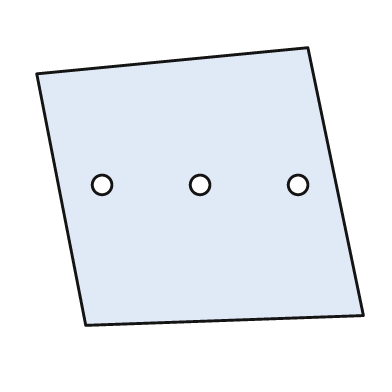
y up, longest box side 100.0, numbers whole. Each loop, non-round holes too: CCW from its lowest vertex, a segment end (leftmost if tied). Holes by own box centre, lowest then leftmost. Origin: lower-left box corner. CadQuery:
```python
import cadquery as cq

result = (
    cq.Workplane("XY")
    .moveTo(15.0, 0.0)
    .lineTo(100.0, 3.0)
    .lineTo(83.0, 85.0)
    .lineTo(0.0, 77.0)
    .close()
    .moveTo(20.0, 43.0)
    .circle(3.0)
    .moveTo(50.0, 43.0)
    .circle(3.0)
    .moveTo(80.0, 43.0)
    .circle(3.0)
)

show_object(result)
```